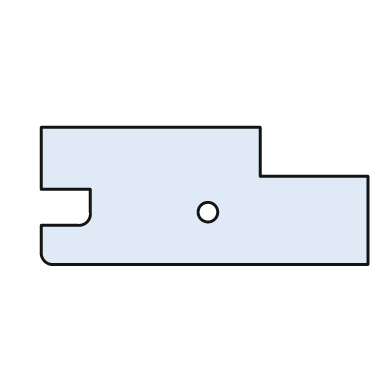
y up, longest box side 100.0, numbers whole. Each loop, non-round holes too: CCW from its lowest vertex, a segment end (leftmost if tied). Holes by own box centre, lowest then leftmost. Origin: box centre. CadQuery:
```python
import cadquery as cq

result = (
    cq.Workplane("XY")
    .moveTo(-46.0, -21.0)
    .lineTo(50.0, -21.0)
    .lineTo(50.0, 6.0)
    .lineTo(17.0, 6.0)
    .lineTo(17.0, 21.0)
    .lineTo(-50.0, 21.0)
    .lineTo(-50.0, 2.0)
    .lineTo(-35.0, 2.0)
    .lineTo(-35.0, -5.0)
    .threePointArc((-36.0, -8.0), (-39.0, -9.0))
    .lineTo(-50.0, -9.0)
    .lineTo(-50.0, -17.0)
    .threePointArc((-49.0, -20.0), (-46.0, -21.0))
    .close()
    .moveTo(1.0, -5.0)
    .circle(3.0)
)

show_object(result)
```